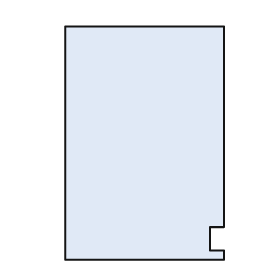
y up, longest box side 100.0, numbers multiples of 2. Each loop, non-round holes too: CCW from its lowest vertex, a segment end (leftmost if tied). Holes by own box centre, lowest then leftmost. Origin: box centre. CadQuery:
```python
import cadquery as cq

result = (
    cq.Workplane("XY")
    .moveTo(-34.0, -50.0)
    .lineTo(34.0, -50.0)
    .lineTo(34.0, -46.0)
    .lineTo(28.0, -46.0)
    .lineTo(28.0, -36.0)
    .lineTo(34.0, -36.0)
    .lineTo(34.0, 50.0)
    .lineTo(-34.0, 50.0)
    .close()
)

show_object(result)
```